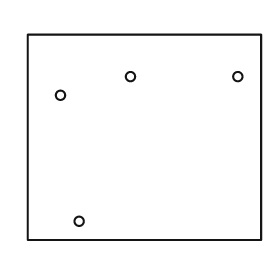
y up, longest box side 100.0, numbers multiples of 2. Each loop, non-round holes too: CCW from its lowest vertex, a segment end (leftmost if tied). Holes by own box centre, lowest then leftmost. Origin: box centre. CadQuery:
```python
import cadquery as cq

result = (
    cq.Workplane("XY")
    .moveTo(-50.0, -44.0)
    .lineTo(50.0, -44.0)
    .lineTo(50.0, 44.0)
    .lineTo(-50.0, 44.0)
    .close()
    .moveTo(-28.0, -36.0)
    .circle(2.0)
    .moveTo(-36.0, 18.0)
    .circle(2.0)
    .moveTo(-6.0, 26.0)
    .circle(2.0)
    .moveTo(40.0, 26.0)
    .circle(2.0)
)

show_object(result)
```